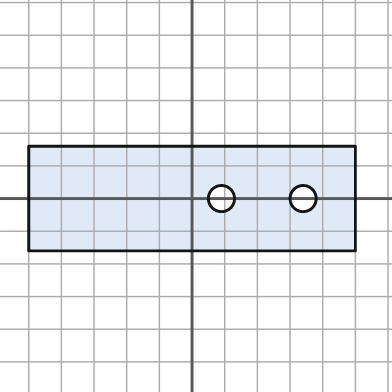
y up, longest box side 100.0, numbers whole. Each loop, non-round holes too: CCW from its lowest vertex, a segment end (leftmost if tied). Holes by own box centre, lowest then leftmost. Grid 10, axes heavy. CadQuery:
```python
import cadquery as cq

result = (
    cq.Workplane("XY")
    .moveTo(-50.0, -16.0)
    .lineTo(50.0, -16.0)
    .lineTo(50.0, 16.0)
    .lineTo(-50.0, 16.0)
    .close()
    .moveTo(9.0, 0.0)
    .circle(4.0)
    .moveTo(34.0, 0.0)
    .circle(4.0)
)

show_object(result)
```